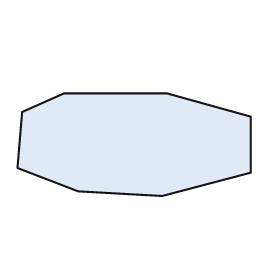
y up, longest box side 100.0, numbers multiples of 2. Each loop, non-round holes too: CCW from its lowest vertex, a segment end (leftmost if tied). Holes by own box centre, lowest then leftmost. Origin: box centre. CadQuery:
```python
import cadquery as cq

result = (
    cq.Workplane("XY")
    .moveTo(12.0, -22.0)
    .lineTo(50.0, -12.0)
    .lineTo(50.0, 12.0)
    .lineTo(14.0, 22.0)
    .lineTo(-30.0, 22.0)
    .lineTo(-48.0, 14.0)
    .lineTo(-50.0, -10.0)
    .lineTo(-24.0, -20.0)
    .close()
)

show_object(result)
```